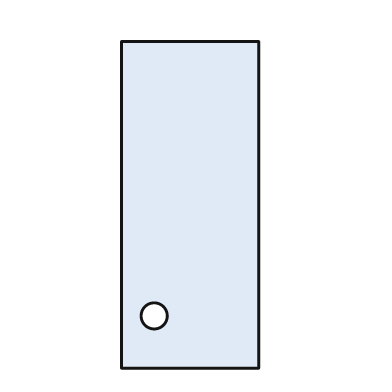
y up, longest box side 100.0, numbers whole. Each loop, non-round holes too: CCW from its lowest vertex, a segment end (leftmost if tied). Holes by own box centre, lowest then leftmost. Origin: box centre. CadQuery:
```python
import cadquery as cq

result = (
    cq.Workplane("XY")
    .moveTo(-21.0, -50.0)
    .lineTo(21.0, -50.0)
    .lineTo(21.0, 50.0)
    .lineTo(-21.0, 50.0)
    .close()
    .moveTo(-11.0, -34.0)
    .circle(4.0)
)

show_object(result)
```